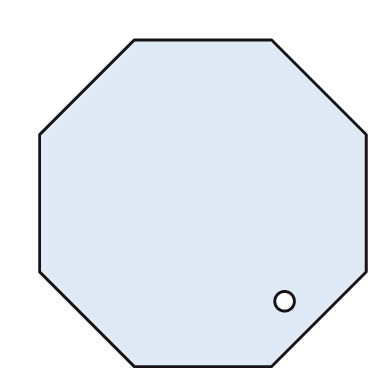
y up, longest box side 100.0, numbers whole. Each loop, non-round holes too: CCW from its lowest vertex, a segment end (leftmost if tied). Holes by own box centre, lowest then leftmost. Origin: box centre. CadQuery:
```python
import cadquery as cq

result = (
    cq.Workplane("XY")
    .moveTo(-21.0, -50.0)
    .lineTo(21.0, -50.0)
    .lineTo(50.0, -21.0)
    .lineTo(50.0, 21.0)
    .lineTo(21.0, 50.0)
    .lineTo(-21.0, 50.0)
    .lineTo(-50.0, 21.0)
    .lineTo(-50.0, -21.0)
    .close()
    .moveTo(25.0, -30.0)
    .circle(3.0)
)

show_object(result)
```